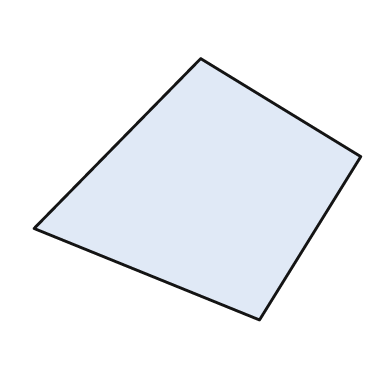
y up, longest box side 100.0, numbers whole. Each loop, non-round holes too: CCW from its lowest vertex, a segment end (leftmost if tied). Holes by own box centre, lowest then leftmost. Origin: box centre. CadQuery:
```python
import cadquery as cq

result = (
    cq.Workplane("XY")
    .moveTo(19.0, -40.0)
    .lineTo(50.0, 10.0)
    .lineTo(1.0, 40.0)
    .lineTo(-50.0, -12.0)
    .close()
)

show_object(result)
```